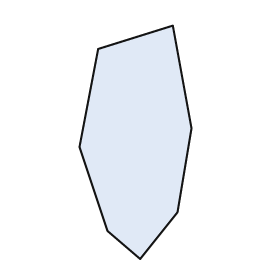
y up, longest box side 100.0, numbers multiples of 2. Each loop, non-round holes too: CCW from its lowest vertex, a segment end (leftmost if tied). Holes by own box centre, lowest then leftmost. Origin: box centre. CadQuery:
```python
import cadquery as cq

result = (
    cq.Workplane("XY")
    .moveTo(2.0, -50.0)
    .lineTo(18.0, -30.0)
    .lineTo(24.0, 6.0)
    .lineTo(16.0, 50.0)
    .lineTo(-16.0, 40.0)
    .lineTo(-24.0, -2.0)
    .lineTo(-12.0, -38.0)
    .close()
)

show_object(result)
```